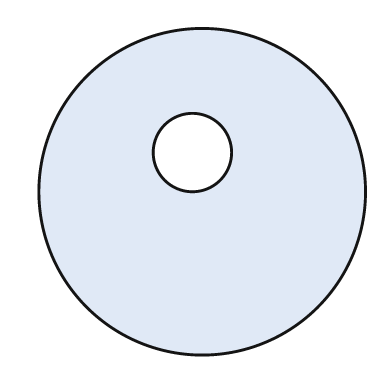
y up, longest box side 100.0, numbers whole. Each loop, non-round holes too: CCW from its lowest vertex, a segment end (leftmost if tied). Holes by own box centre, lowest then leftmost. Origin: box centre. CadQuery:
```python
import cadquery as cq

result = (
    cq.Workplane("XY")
    .moveTo(0.0, 0.0)
    .circle(50.0)
    .moveTo(-3.0, 12.0)
    .circle(12.0)
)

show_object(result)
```